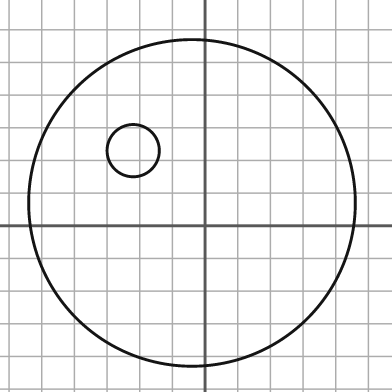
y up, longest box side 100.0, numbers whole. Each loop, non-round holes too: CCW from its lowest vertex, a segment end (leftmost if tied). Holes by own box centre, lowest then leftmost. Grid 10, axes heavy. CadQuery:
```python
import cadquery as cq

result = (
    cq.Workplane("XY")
    .moveTo(-4.0, 7.0)
    .circle(50.0)
    .moveTo(-22.0, 23.0)
    .circle(8.0)
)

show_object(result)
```